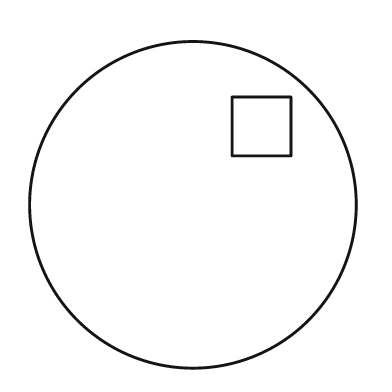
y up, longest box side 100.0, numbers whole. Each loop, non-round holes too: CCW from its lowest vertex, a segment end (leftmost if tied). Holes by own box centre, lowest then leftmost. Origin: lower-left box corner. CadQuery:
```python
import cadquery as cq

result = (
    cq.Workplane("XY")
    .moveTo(50.0, 50.0)
    .circle(50.0)
    .moveTo(62.0, 65.0)
    .lineTo(80.0, 65.0)
    .lineTo(80.0, 83.0)
    .lineTo(62.0, 83.0)
    .close()
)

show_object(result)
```